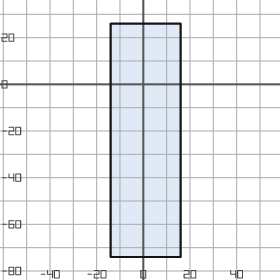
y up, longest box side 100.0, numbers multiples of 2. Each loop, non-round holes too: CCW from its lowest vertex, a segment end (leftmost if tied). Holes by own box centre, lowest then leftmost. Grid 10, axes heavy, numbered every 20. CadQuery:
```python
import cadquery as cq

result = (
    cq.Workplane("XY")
    .moveTo(-14.0, -74.0)
    .lineTo(16.0, -74.0)
    .lineTo(16.0, 26.0)
    .lineTo(-14.0, 26.0)
    .close()
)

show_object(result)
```